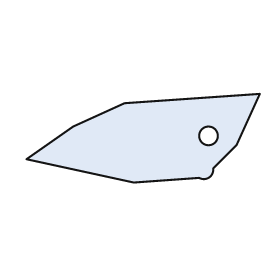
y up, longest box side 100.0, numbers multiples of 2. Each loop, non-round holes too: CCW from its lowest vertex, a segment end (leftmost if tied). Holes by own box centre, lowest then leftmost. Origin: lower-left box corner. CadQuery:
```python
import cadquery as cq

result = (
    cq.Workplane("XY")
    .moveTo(46.0, 0.0)
    .lineTo(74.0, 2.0)
    .threePointArc((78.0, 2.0), (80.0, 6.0))
    .lineTo(90.0, 16.0)
    .lineTo(100.0, 38.0)
    .lineTo(42.0, 34.0)
    .lineTo(20.0, 24.0)
    .lineTo(0.0, 10.0)
    .close()
    .moveTo(78.0, 20.0)
    .circle(4.0)
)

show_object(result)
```